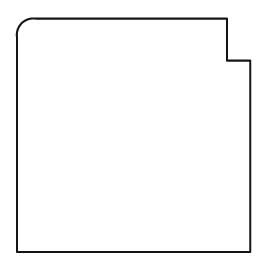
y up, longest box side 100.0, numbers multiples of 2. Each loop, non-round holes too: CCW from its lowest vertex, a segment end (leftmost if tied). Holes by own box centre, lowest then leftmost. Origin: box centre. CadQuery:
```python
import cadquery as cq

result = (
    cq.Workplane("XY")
    .moveTo(-50.0, -50.0)
    .lineTo(50.0, -50.0)
    .lineTo(50.0, 32.0)
    .lineTo(40.0, 32.0)
    .lineTo(40.0, 50.0)
    .lineTo(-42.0, 50.0)
    .threePointArc((-48.0, 48.0), (-50.0, 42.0))
    .close()
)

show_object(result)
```